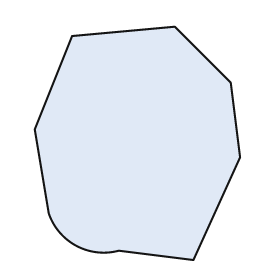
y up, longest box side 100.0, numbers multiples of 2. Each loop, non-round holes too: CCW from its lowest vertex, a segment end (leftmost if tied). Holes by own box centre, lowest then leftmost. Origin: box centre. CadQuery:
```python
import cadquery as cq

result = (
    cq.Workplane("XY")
    .moveTo(24.0, -50.0)
    .lineTo(44.0, -6.0)
    .lineTo(40.0, 26.0)
    .lineTo(16.0, 50.0)
    .lineTo(-28.0, 46.0)
    .lineTo(-44.0, 6.0)
    .lineTo(-38.0, -30.0)
    .threePointArc((-26.0, -44.0), (-8.0, -46.0))
    .close()
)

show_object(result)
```